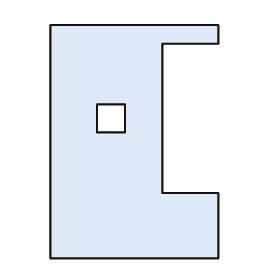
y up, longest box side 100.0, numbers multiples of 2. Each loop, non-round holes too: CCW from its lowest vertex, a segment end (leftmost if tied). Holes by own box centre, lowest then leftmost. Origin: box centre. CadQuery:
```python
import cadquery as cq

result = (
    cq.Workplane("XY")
    .moveTo(-36.0, -50.0)
    .lineTo(36.0, -50.0)
    .lineTo(36.0, -22.0)
    .lineTo(12.0, -22.0)
    .lineTo(12.0, 42.0)
    .lineTo(36.0, 42.0)
    .lineTo(36.0, 50.0)
    .lineTo(-36.0, 50.0)
    .close()
    .moveTo(-16.0, 4.0)
    .lineTo(-4.0, 4.0)
    .lineTo(-4.0, 16.0)
    .lineTo(-16.0, 16.0)
    .close()
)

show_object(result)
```